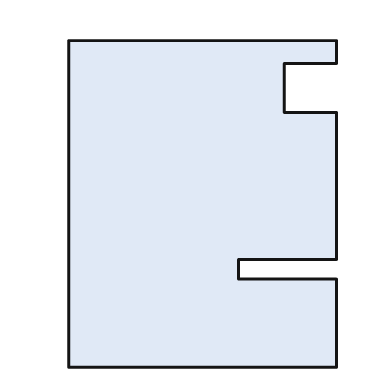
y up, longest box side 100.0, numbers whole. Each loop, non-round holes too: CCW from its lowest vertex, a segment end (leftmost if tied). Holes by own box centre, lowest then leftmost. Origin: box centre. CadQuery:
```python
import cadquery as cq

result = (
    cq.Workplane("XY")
    .moveTo(-41.0, -50.0)
    .lineTo(41.0, -50.0)
    .lineTo(41.0, -23.0)
    .lineTo(11.0, -23.0)
    .lineTo(11.0, -17.0)
    .lineTo(41.0, -17.0)
    .lineTo(41.0, 28.0)
    .lineTo(25.0, 28.0)
    .lineTo(25.0, 43.0)
    .lineTo(41.0, 43.0)
    .lineTo(41.0, 50.0)
    .lineTo(-41.0, 50.0)
    .close()
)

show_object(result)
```